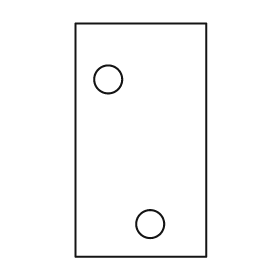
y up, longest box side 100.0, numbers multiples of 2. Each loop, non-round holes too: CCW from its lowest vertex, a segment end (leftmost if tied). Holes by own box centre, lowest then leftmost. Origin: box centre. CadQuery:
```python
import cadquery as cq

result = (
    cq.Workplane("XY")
    .moveTo(-28.0, -50.0)
    .lineTo(28.0, -50.0)
    .lineTo(28.0, 50.0)
    .lineTo(-28.0, 50.0)
    .close()
    .moveTo(4.0, -36.0)
    .circle(6.0)
    .moveTo(-14.0, 26.0)
    .circle(6.0)
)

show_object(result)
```